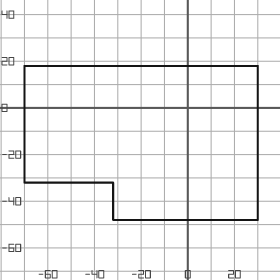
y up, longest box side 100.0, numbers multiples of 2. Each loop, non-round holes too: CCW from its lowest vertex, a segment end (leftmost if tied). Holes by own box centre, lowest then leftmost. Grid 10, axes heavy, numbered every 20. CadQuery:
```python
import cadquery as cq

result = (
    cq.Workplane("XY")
    .moveTo(-32.0, -48.0)
    .lineTo(30.0, -48.0)
    .lineTo(30.0, 18.0)
    .lineTo(-70.0, 18.0)
    .lineTo(-70.0, -32.0)
    .lineTo(-32.0, -32.0)
    .close()
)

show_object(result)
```